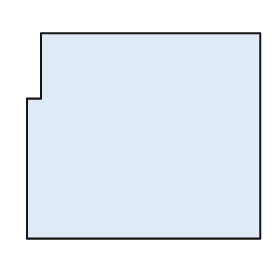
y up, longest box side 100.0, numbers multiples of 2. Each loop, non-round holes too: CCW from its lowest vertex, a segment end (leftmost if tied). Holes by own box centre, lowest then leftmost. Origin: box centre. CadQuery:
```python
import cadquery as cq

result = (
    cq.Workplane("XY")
    .moveTo(-50.0, -44.0)
    .lineTo(50.0, -44.0)
    .lineTo(50.0, 44.0)
    .lineTo(-44.0, 44.0)
    .lineTo(-44.0, 16.0)
    .lineTo(-50.0, 16.0)
    .close()
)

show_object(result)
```